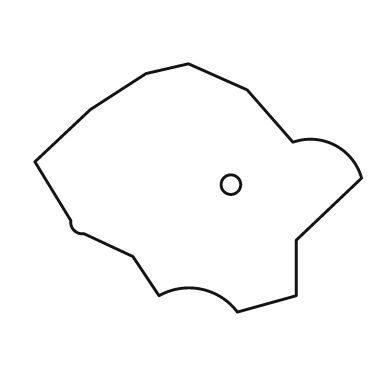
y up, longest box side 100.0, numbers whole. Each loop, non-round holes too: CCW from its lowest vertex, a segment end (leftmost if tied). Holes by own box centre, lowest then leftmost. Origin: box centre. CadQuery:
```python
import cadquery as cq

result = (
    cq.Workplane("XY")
    .moveTo(12.0, -38.0)
    .lineTo(30.0, -33.0)
    .lineTo(30.0, -16.0)
    .lineTo(50.0, 3.0)
    .threePointArc((42.0, 13.0), (29.0, 14.0))
    .lineTo(15.0, 30.0)
    .lineTo(-3.0, 38.0)
    .lineTo(-16.0, 35.0)
    .lineTo(-33.0, 24.0)
    .lineTo(-50.0, 8.0)
    .lineTo(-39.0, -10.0)
    .threePointArc((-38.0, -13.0), (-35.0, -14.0))
    .lineTo(-20.0, -21.0)
    .lineTo(-12.0, -33.0)
    .threePointArc((1.0, -31.0), (12.0, -38.0))
    .close()
    .moveTo(10.0, 1.0)
    .circle(3.0)
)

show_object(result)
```